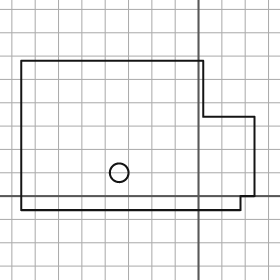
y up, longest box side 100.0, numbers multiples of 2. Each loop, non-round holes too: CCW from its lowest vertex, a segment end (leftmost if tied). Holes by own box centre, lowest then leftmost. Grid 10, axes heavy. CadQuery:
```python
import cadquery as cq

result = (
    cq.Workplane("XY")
    .moveTo(-76.0, -6.0)
    .lineTo(18.0, -6.0)
    .lineTo(18.0, 0.0)
    .lineTo(24.0, 0.0)
    .lineTo(24.0, 34.0)
    .lineTo(2.0, 34.0)
    .lineTo(2.0, 58.0)
    .lineTo(-76.0, 58.0)
    .close()
    .moveTo(-34.0, 10.0)
    .circle(4.0)
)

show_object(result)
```